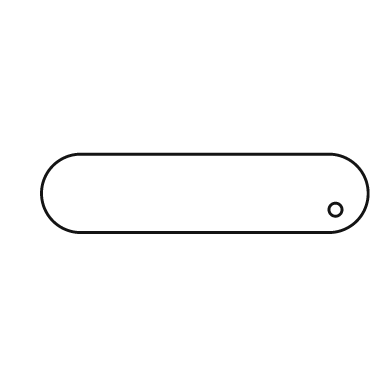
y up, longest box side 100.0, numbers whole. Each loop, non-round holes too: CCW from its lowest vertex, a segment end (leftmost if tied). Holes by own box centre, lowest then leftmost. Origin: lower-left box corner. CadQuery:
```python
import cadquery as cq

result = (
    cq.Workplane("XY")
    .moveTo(12.0, 0.0)
    .lineTo(88.0, 0.0)
    .threePointArc((100.0, 12.0), (88.0, 24.0))
    .lineTo(12.0, 24.0)
    .threePointArc((0.0, 12.0), (12.0, 0.0))
    .close()
    .moveTo(90.0, 7.0)
    .circle(2.0)
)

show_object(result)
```